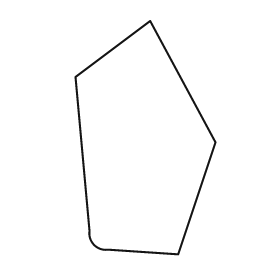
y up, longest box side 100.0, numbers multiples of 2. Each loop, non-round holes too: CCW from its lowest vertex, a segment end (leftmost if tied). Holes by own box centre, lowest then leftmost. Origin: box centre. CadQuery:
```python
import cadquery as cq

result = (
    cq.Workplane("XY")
    .moveTo(14.0, -50.0)
    .lineTo(30.0, -2.0)
    .lineTo(2.0, 50.0)
    .lineTo(-30.0, 26.0)
    .lineTo(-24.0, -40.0)
    .threePointArc((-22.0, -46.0), (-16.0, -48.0))
    .close()
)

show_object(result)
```